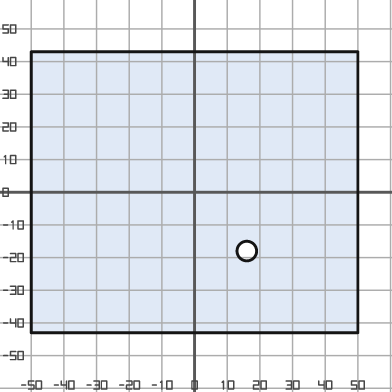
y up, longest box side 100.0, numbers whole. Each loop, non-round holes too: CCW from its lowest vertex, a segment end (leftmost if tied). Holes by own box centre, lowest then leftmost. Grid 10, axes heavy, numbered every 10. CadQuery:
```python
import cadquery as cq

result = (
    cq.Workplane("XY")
    .moveTo(-50.0, -43.0)
    .lineTo(50.0, -43.0)
    .lineTo(50.0, 43.0)
    .lineTo(-50.0, 43.0)
    .close()
    .moveTo(16.0, -18.0)
    .circle(3.0)
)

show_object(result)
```